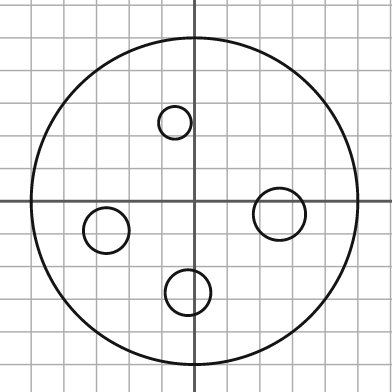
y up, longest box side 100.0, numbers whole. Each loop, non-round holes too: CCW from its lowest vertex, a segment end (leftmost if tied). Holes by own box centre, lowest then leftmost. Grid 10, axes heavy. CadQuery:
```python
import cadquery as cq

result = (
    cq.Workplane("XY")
    .moveTo(0.0, 0.0)
    .circle(50.0)
    .moveTo(-2.0, -28.0)
    .circle(7.0)
    .moveTo(-27.0, -9.0)
    .circle(7.0)
    .moveTo(26.0, -4.0)
    .circle(8.0)
    .moveTo(-6.0, 24.0)
    .circle(5.0)
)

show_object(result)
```